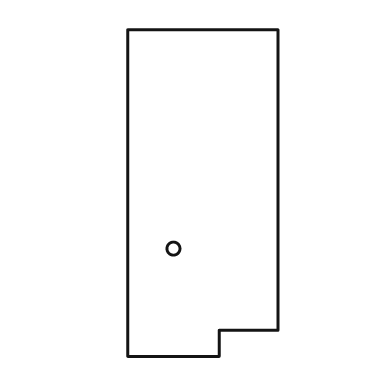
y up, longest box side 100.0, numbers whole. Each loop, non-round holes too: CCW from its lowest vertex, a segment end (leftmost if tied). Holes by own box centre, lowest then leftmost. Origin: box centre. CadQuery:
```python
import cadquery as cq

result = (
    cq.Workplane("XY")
    .moveTo(-23.0, -50.0)
    .lineTo(5.0, -50.0)
    .lineTo(5.0, -42.0)
    .lineTo(23.0, -42.0)
    .lineTo(23.0, 50.0)
    .lineTo(-23.0, 50.0)
    .close()
    .moveTo(-9.0, -17.0)
    .circle(2.0)
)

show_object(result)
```